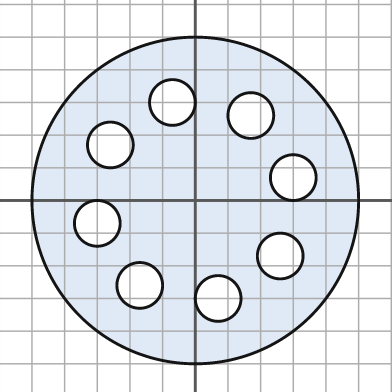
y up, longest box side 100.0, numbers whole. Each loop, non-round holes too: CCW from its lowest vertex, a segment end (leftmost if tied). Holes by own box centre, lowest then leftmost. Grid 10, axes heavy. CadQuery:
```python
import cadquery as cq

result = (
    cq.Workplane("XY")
    .moveTo(0.0, 0.0)
    .circle(50.0)
    .moveTo(7.0, -30.0)
    .circle(7.0)
    .moveTo(-17.0, -26.0)
    .circle(7.0)
    .moveTo(26.0, -17.0)
    .circle(7.0)
    .moveTo(-30.0, -7.0)
    .circle(7.0)
    .moveTo(30.0, 7.0)
    .circle(7.0)
    .moveTo(-26.0, 17.0)
    .circle(7.0)
    .moveTo(17.0, 26.0)
    .circle(7.0)
    .moveTo(-7.0, 30.0)
    .circle(7.0)
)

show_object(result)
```